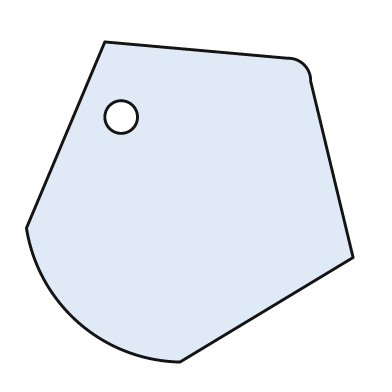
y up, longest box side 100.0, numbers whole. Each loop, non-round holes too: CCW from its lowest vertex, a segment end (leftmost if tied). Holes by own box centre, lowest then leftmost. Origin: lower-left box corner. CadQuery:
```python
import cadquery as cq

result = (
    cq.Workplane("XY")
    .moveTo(47.0, 0.0)
    .lineTo(100.0, 32.0)
    .lineTo(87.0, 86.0)
    .threePointArc((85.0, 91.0), (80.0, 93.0))
    .lineTo(24.0, 98.0)
    .lineTo(0.0, 41.0)
    .threePointArc((16.0, 12.0), (47.0, 0.0))
    .close()
    .moveTo(29.0, 75.0)
    .circle(5.0)
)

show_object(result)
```